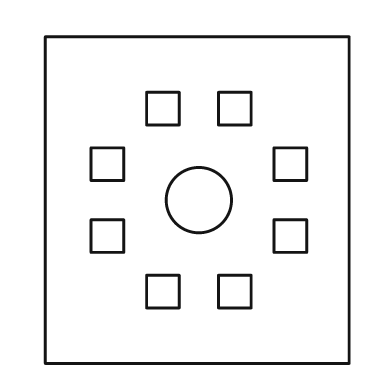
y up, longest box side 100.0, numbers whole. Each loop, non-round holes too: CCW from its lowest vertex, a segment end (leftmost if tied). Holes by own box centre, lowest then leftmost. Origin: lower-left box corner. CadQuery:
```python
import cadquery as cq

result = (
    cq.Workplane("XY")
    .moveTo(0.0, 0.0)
    .lineTo(93.0, 0.0)
    .lineTo(93.0, 100.0)
    .lineTo(0.0, 100.0)
    .close()
    .moveTo(31.0, 17.0)
    .lineTo(41.0, 17.0)
    .lineTo(41.0, 27.0)
    .lineTo(31.0, 27.0)
    .close()
    .moveTo(53.0, 17.0)
    .lineTo(63.0, 17.0)
    .lineTo(63.0, 27.0)
    .lineTo(53.0, 27.0)
    .close()
    .moveTo(14.0, 34.0)
    .lineTo(24.0, 34.0)
    .lineTo(24.0, 44.0)
    .lineTo(14.0, 44.0)
    .close()
    .moveTo(70.0, 34.0)
    .lineTo(80.0, 34.0)
    .lineTo(80.0, 44.0)
    .lineTo(70.0, 44.0)
    .close()
    .moveTo(47.0, 50.0)
    .circle(10.0)
    .moveTo(14.0, 56.0)
    .lineTo(24.0, 56.0)
    .lineTo(24.0, 66.0)
    .lineTo(14.0, 66.0)
    .close()
    .moveTo(70.0, 56.0)
    .lineTo(80.0, 56.0)
    .lineTo(80.0, 66.0)
    .lineTo(70.0, 66.0)
    .close()
    .moveTo(31.0, 73.0)
    .lineTo(41.0, 73.0)
    .lineTo(41.0, 83.0)
    .lineTo(31.0, 83.0)
    .close()
    .moveTo(53.0, 73.0)
    .lineTo(63.0, 73.0)
    .lineTo(63.0, 83.0)
    .lineTo(53.0, 83.0)
    .close()
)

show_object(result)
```